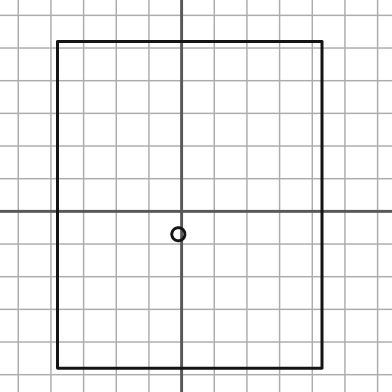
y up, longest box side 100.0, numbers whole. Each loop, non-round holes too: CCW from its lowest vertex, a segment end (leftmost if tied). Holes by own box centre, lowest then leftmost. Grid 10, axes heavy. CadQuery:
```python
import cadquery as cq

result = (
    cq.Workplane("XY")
    .moveTo(-38.0, -48.0)
    .lineTo(43.0, -48.0)
    .lineTo(43.0, 52.0)
    .lineTo(-38.0, 52.0)
    .close()
    .moveTo(-1.0, -7.0)
    .circle(2.0)
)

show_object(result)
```